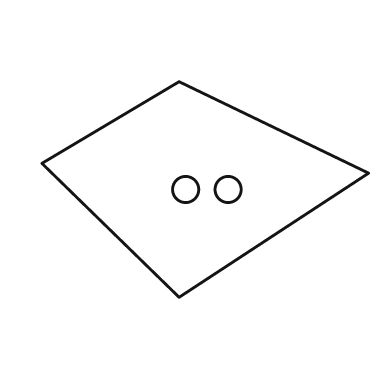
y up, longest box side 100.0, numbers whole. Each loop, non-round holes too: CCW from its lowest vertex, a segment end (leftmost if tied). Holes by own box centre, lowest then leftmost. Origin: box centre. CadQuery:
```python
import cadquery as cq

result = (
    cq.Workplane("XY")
    .moveTo(-8.0, -33.0)
    .lineTo(50.0, 5.0)
    .lineTo(-8.0, 33.0)
    .lineTo(-50.0, 8.0)
    .close()
    .moveTo(-6.0, 0.0)
    .circle(4.0)
    .moveTo(7.0, 0.0)
    .circle(4.0)
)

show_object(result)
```